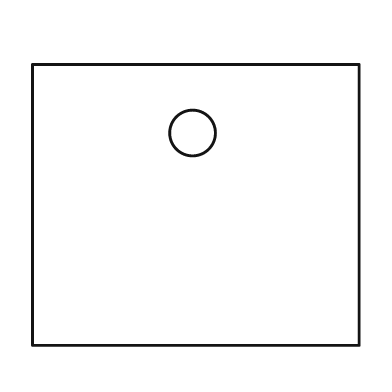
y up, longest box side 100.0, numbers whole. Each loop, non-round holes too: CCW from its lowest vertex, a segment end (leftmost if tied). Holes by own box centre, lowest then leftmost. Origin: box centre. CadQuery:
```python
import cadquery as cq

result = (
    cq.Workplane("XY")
    .moveTo(-50.0, -43.0)
    .lineTo(50.0, -43.0)
    .lineTo(50.0, 43.0)
    .lineTo(-50.0, 43.0)
    .close()
    .moveTo(-1.0, 22.0)
    .circle(7.0)
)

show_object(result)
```